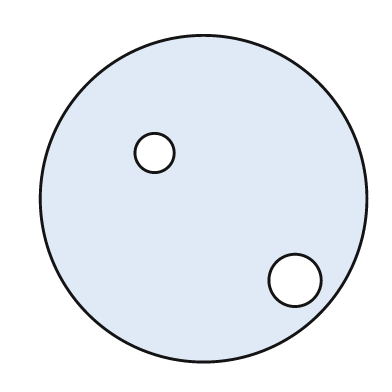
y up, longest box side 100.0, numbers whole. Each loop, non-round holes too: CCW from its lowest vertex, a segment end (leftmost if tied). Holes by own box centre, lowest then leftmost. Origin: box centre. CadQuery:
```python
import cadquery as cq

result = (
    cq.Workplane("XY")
    .moveTo(0.0, 0.0)
    .circle(50.0)
    .moveTo(28.0, -25.0)
    .circle(8.0)
    .moveTo(-15.0, 14.0)
    .circle(6.0)
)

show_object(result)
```